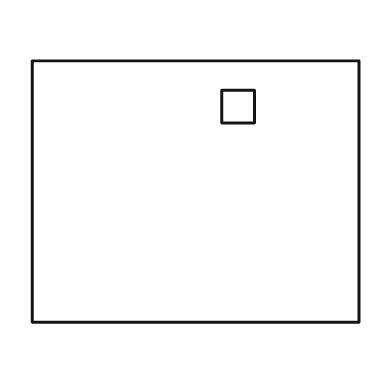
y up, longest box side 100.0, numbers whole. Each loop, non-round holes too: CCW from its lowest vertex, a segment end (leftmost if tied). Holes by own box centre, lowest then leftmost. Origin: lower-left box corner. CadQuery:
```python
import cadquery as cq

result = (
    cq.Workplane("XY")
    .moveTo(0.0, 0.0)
    .lineTo(100.0, 0.0)
    .lineTo(100.0, 80.0)
    .lineTo(0.0, 80.0)
    .close()
    .moveTo(58.0, 61.0)
    .lineTo(68.0, 61.0)
    .lineTo(68.0, 71.0)
    .lineTo(58.0, 71.0)
    .close()
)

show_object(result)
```